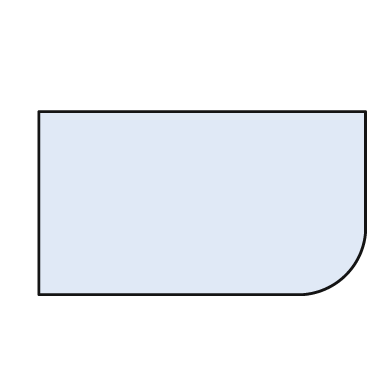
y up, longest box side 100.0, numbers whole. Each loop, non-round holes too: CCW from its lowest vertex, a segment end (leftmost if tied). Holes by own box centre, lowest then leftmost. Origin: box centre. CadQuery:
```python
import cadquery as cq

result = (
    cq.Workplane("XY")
    .moveTo(-50.0, -28.0)
    .lineTo(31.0, -28.0)
    .threePointArc((44.0, -22.0), (50.0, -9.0))
    .lineTo(50.0, 28.0)
    .lineTo(-50.0, 28.0)
    .close()
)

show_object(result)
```